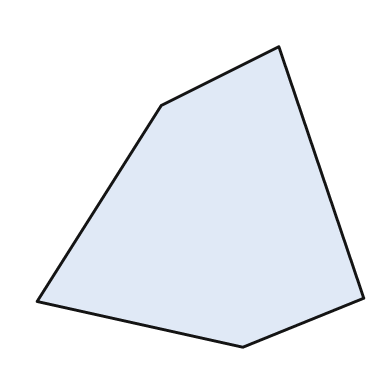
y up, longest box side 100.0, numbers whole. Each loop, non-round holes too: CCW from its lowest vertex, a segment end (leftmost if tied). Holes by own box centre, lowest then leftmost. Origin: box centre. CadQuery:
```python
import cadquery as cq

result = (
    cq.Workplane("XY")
    .moveTo(13.0, -46.0)
    .lineTo(50.0, -31.0)
    .lineTo(24.0, 46.0)
    .lineTo(-12.0, 28.0)
    .lineTo(-50.0, -32.0)
    .close()
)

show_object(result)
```